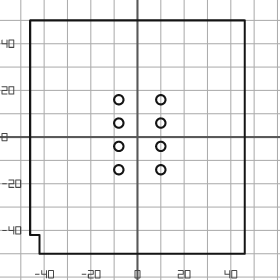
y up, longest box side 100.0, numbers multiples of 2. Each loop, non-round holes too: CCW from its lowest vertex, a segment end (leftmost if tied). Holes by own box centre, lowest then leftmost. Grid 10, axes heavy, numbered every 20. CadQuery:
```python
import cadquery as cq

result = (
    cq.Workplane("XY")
    .moveTo(-42.0, -50.0)
    .lineTo(46.0, -50.0)
    .lineTo(46.0, 50.0)
    .lineTo(-46.0, 50.0)
    .lineTo(-46.0, -42.0)
    .lineTo(-42.0, -42.0)
    .close()
    .moveTo(-8.0, -14.0)
    .circle(2.0)
    .moveTo(10.0, -14.0)
    .circle(2.0)
    .moveTo(-8.0, -4.0)
    .circle(2.0)
    .moveTo(10.0, -4.0)
    .circle(2.0)
    .moveTo(-8.0, 6.0)
    .circle(2.0)
    .moveTo(10.0, 6.0)
    .circle(2.0)
    .moveTo(-8.0, 16.0)
    .circle(2.0)
    .moveTo(10.0, 16.0)
    .circle(2.0)
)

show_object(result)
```